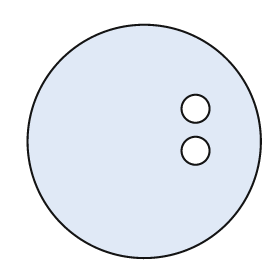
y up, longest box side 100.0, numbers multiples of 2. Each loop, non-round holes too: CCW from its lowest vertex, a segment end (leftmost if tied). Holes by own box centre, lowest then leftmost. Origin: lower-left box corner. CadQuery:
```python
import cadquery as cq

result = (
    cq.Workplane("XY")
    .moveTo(50.0, 50.0)
    .circle(50.0)
    .moveTo(72.0, 46.0)
    .circle(6.0)
    .moveTo(72.0, 64.0)
    .circle(6.0)
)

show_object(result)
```